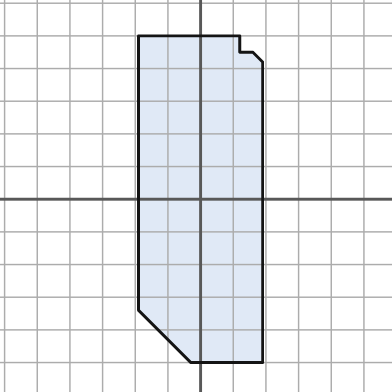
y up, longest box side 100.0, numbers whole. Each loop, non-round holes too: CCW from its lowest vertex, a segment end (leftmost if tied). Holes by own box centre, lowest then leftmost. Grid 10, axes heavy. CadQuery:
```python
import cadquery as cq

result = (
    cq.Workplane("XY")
    .moveTo(-3.0, -50.0)
    .lineTo(19.0, -50.0)
    .lineTo(19.0, 42.0)
    .lineTo(16.0, 45.0)
    .lineTo(12.0, 45.0)
    .lineTo(12.0, 50.0)
    .lineTo(-19.0, 50.0)
    .lineTo(-19.0, -34.0)
    .close()
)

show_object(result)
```